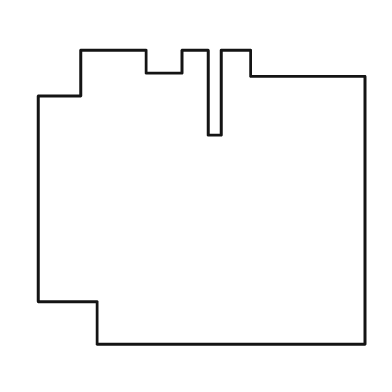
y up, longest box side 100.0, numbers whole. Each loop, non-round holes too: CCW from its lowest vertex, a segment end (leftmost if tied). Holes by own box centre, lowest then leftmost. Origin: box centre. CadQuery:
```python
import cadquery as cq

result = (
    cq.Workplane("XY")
    .moveTo(-32.0, -45.0)
    .lineTo(50.0, -45.0)
    .lineTo(50.0, 37.0)
    .lineTo(15.0, 37.0)
    .lineTo(15.0, 45.0)
    .lineTo(6.0, 45.0)
    .lineTo(6.0, 19.0)
    .lineTo(2.0, 19.0)
    .lineTo(2.0, 45.0)
    .lineTo(-6.0, 45.0)
    .lineTo(-6.0, 38.0)
    .lineTo(-17.0, 38.0)
    .lineTo(-17.0, 45.0)
    .lineTo(-37.0, 45.0)
    .lineTo(-37.0, 31.0)
    .lineTo(-50.0, 31.0)
    .lineTo(-50.0, -32.0)
    .lineTo(-32.0, -32.0)
    .close()
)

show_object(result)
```